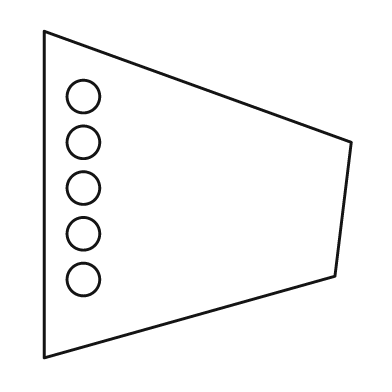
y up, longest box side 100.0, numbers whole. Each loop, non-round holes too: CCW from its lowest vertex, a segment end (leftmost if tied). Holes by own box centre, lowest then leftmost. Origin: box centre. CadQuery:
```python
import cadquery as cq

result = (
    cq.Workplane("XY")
    .moveTo(-47.0, -50.0)
    .lineTo(42.0, -25.0)
    .lineTo(47.0, 16.0)
    .lineTo(-47.0, 50.0)
    .close()
    .moveTo(-35.0, -26.0)
    .circle(5.0)
    .moveTo(-35.0, -12.0)
    .circle(5.0)
    .moveTo(-35.0, 2.0)
    .circle(5.0)
    .moveTo(-35.0, 16.0)
    .circle(5.0)
    .moveTo(-35.0, 30.0)
    .circle(5.0)
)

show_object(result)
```